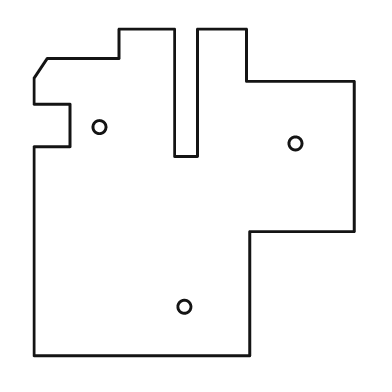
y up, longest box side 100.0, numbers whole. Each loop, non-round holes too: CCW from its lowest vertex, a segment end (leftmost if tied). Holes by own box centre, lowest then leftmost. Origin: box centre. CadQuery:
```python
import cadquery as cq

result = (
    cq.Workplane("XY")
    .moveTo(-49.0, -50.0)
    .lineTo(17.0, -50.0)
    .lineTo(17.0, -12.0)
    .lineTo(49.0, -12.0)
    .lineTo(49.0, 34.0)
    .lineTo(16.0, 34.0)
    .lineTo(16.0, 50.0)
    .lineTo(1.0, 50.0)
    .lineTo(1.0, 11.0)
    .lineTo(-6.0, 11.0)
    .lineTo(-6.0, 50.0)
    .lineTo(-23.0, 50.0)
    .lineTo(-23.0, 41.0)
    .lineTo(-45.0, 41.0)
    .lineTo(-49.0, 35.0)
    .lineTo(-49.0, 27.0)
    .lineTo(-38.0, 27.0)
    .lineTo(-38.0, 14.0)
    .lineTo(-49.0, 14.0)
    .close()
    .moveTo(-3.0, -35.0)
    .circle(2.0)
    .moveTo(31.0, 15.0)
    .circle(2.0)
    .moveTo(-29.0, 20.0)
    .circle(2.0)
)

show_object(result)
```